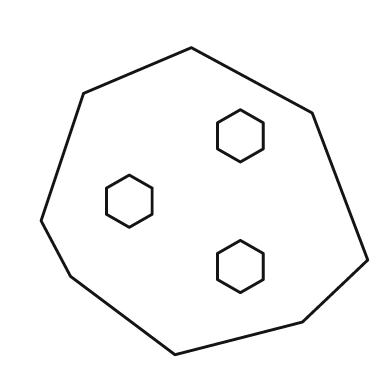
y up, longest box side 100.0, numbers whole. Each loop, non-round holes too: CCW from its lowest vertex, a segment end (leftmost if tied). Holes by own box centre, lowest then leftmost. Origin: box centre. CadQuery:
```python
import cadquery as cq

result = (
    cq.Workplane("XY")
    .moveTo(-9.0, -47.0)
    .lineTo(30.0, -37.0)
    .lineTo(50.0, -18.0)
    .lineTo(33.0, 27.0)
    .lineTo(-4.0, 47.0)
    .lineTo(-37.0, 33.0)
    .lineTo(-50.0, -6.0)
    .lineTo(-41.0, -23.0)
    .close()
    .moveTo(11.0, -28.0)
    .lineTo(18.0, -24.0)
    .lineTo(18.0, -16.0)
    .lineTo(11.0, -12.0)
    .lineTo(4.0, -16.0)
    .lineTo(4.0, -24.0)
    .close()
    .moveTo(-23.0, -8.0)
    .lineTo(-16.0, -4.0)
    .lineTo(-16.0, 4.0)
    .lineTo(-23.0, 8.0)
    .lineTo(-30.0, 4.0)
    .lineTo(-30.0, -4.0)
    .close()
    .moveTo(11.0, 12.0)
    .lineTo(18.0, 16.0)
    .lineTo(18.0, 24.0)
    .lineTo(11.0, 28.0)
    .lineTo(4.0, 24.0)
    .lineTo(4.0, 16.0)
    .close()
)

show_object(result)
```